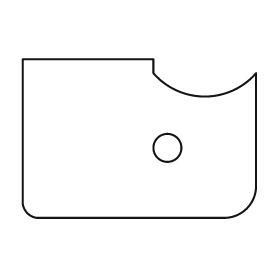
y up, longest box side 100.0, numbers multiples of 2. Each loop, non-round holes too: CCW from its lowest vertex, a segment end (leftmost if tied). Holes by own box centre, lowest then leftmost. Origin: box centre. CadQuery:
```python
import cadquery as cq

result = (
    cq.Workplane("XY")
    .moveTo(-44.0, -34.0)
    .lineTo(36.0, -34.0)
    .threePointArc((46.0, -30.0), (50.0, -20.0))
    .lineTo(50.0, 28.0)
    .threePointArc((28.0, 18.0), (6.0, 28.0))
    .lineTo(6.0, 34.0)
    .lineTo(-50.0, 34.0)
    .lineTo(-50.0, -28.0)
    .threePointArc((-48.0, -32.0), (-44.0, -34.0))
    .close()
    .moveTo(12.0, -4.0)
    .circle(6.0)
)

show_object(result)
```